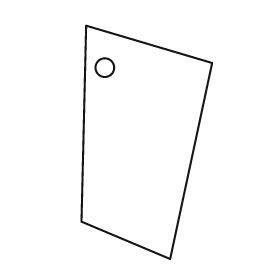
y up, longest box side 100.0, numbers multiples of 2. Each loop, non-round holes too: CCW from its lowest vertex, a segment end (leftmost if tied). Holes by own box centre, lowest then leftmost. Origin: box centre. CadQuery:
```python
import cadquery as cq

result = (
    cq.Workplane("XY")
    .moveTo(10.0, -50.0)
    .lineTo(28.0, 34.0)
    .lineTo(-26.0, 50.0)
    .lineTo(-28.0, -34.0)
    .close()
    .moveTo(-18.0, 32.0)
    .circle(4.0)
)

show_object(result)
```